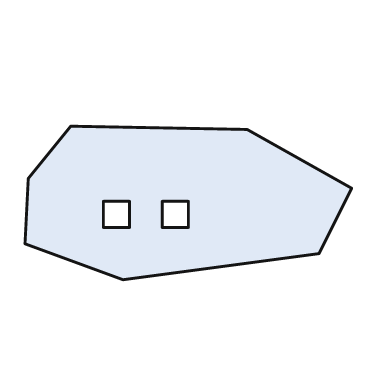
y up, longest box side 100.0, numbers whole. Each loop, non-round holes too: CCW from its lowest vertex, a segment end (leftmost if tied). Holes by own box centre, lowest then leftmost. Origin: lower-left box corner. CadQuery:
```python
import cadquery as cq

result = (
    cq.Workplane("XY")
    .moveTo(30.0, 0.0)
    .lineTo(90.0, 8.0)
    .lineTo(100.0, 28.0)
    .lineTo(68.0, 46.0)
    .lineTo(14.0, 47.0)
    .lineTo(1.0, 31.0)
    .lineTo(0.0, 11.0)
    .close()
    .moveTo(24.0, 16.0)
    .lineTo(32.0, 16.0)
    .lineTo(32.0, 24.0)
    .lineTo(24.0, 24.0)
    .close()
    .moveTo(42.0, 16.0)
    .lineTo(50.0, 16.0)
    .lineTo(50.0, 24.0)
    .lineTo(42.0, 24.0)
    .close()
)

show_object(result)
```